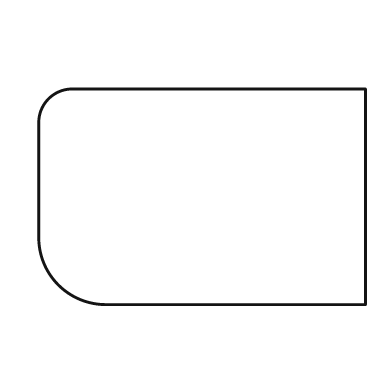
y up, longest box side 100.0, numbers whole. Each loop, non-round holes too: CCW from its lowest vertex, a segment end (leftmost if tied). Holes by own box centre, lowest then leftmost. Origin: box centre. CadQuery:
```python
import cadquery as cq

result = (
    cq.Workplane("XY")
    .moveTo(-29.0, -33.0)
    .lineTo(50.0, -33.0)
    .lineTo(50.0, 33.0)
    .lineTo(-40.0, 33.0)
    .threePointArc((-47.0, 30.0), (-50.0, 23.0))
    .lineTo(-50.0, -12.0)
    .threePointArc((-44.0, -27.0), (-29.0, -33.0))
    .close()
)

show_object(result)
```